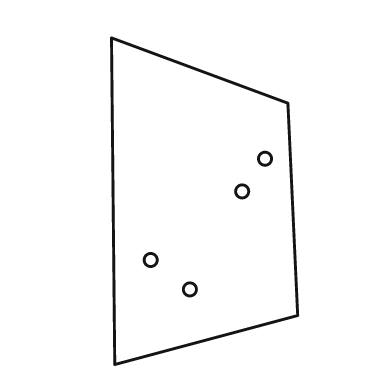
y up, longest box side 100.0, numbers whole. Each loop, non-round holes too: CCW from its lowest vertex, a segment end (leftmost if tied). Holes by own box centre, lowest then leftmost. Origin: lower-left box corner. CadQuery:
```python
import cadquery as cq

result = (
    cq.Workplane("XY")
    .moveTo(1.0, 0.0)
    .lineTo(57.0, 15.0)
    .lineTo(54.0, 80.0)
    .lineTo(0.0, 100.0)
    .close()
    .moveTo(24.0, 23.0)
    .circle(2.0)
    .moveTo(12.0, 32.0)
    .circle(2.0)
    .moveTo(40.0, 53.0)
    .circle(2.0)
    .moveTo(47.0, 63.0)
    .circle(2.0)
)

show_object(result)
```